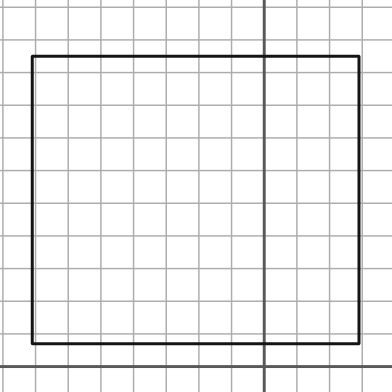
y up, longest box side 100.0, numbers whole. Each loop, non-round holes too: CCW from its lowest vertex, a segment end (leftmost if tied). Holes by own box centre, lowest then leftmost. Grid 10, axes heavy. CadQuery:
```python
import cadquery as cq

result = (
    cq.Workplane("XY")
    .moveTo(-71.0, 7.0)
    .lineTo(29.0, 7.0)
    .lineTo(29.0, 95.0)
    .lineTo(-71.0, 95.0)
    .close()
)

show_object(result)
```